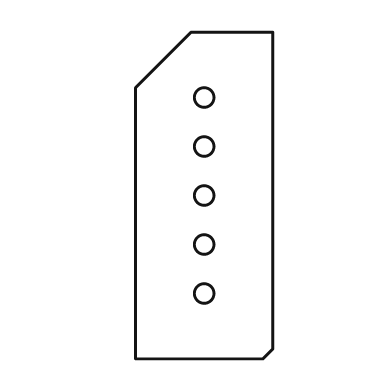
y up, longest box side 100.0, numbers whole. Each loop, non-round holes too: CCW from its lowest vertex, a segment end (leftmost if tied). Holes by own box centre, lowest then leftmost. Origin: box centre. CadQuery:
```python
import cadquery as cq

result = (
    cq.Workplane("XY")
    .moveTo(-21.0, -50.0)
    .lineTo(18.0, -50.0)
    .lineTo(21.0, -47.0)
    .lineTo(21.0, 50.0)
    .lineTo(-4.0, 50.0)
    .lineTo(-21.0, 33.0)
    .close()
    .moveTo(0.0, -30.0)
    .circle(3.0)
    .moveTo(0.0, -15.0)
    .circle(3.0)
    .moveTo(0.0, 0.0)
    .circle(3.0)
    .moveTo(0.0, 15.0)
    .circle(3.0)
    .moveTo(0.0, 30.0)
    .circle(3.0)
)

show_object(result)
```